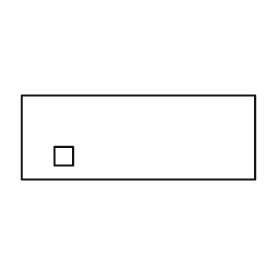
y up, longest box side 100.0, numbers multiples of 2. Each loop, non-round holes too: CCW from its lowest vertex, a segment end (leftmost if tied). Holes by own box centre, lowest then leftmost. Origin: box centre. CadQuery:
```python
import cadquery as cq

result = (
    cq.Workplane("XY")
    .moveTo(-50.0, -18.0)
    .lineTo(50.0, -18.0)
    .lineTo(50.0, 18.0)
    .lineTo(-50.0, 18.0)
    .close()
    .moveTo(-36.0, -12.0)
    .lineTo(-28.0, -12.0)
    .lineTo(-28.0, -4.0)
    .lineTo(-36.0, -4.0)
    .close()
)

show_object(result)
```